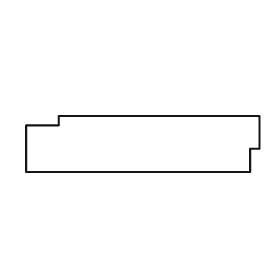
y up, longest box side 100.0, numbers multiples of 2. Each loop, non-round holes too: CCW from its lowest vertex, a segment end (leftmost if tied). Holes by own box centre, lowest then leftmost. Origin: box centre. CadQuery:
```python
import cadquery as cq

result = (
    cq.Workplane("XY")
    .moveTo(-50.0, -12.0)
    .lineTo(46.0, -12.0)
    .lineTo(46.0, -2.0)
    .lineTo(50.0, -2.0)
    .lineTo(50.0, 12.0)
    .lineTo(-36.0, 12.0)
    .lineTo(-36.0, 8.0)
    .lineTo(-50.0, 8.0)
    .close()
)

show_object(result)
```